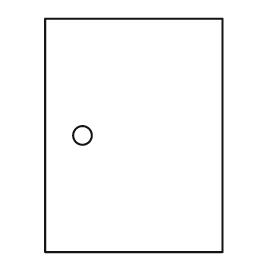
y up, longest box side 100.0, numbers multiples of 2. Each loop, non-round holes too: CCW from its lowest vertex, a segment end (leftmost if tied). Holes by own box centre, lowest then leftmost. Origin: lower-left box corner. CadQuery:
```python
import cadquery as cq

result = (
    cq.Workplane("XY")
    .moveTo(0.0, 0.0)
    .lineTo(76.0, 0.0)
    .lineTo(76.0, 100.0)
    .lineTo(0.0, 100.0)
    .close()
    .moveTo(16.0, 50.0)
    .circle(4.0)
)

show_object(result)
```